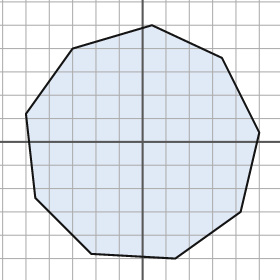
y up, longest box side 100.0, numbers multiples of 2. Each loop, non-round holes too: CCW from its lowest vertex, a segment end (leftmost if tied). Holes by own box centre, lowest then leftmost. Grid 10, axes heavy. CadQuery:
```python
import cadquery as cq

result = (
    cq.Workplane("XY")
    .moveTo(14.0, -50.0)
    .lineTo(42.0, -30.0)
    .lineTo(50.0, 4.0)
    .lineTo(34.0, 36.0)
    .lineTo(4.0, 50.0)
    .lineTo(-30.0, 40.0)
    .lineTo(-50.0, 12.0)
    .lineTo(-46.0, -24.0)
    .lineTo(-22.0, -48.0)
    .close()
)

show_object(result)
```